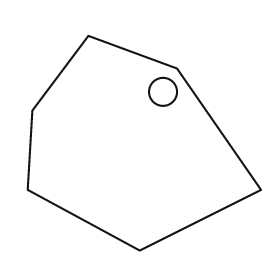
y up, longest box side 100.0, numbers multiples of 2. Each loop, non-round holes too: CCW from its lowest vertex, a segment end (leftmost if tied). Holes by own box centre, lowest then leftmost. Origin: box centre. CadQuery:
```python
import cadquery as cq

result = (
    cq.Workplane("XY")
    .moveTo(-2.0, -46.0)
    .lineTo(50.0, -20.0)
    .lineTo(14.0, 32.0)
    .lineTo(-24.0, 46.0)
    .lineTo(-48.0, 14.0)
    .lineTo(-50.0, -20.0)
    .close()
    .moveTo(8.0, 22.0)
    .circle(6.0)
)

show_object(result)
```